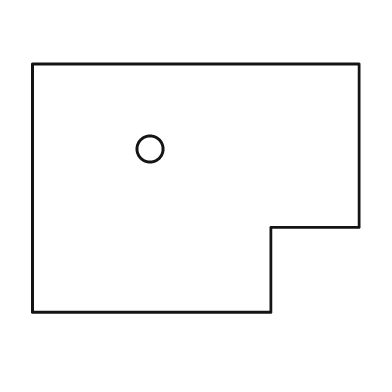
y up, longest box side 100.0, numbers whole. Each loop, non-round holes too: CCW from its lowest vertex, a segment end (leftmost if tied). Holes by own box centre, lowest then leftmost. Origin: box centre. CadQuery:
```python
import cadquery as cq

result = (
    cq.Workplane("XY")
    .moveTo(-50.0, -38.0)
    .lineTo(23.0, -38.0)
    .lineTo(23.0, -12.0)
    .lineTo(50.0, -12.0)
    .lineTo(50.0, 38.0)
    .lineTo(-50.0, 38.0)
    .close()
    .moveTo(-14.0, 12.0)
    .circle(4.0)
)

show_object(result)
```